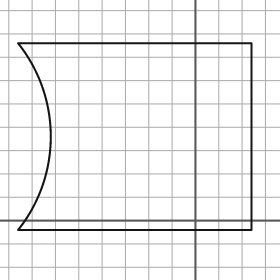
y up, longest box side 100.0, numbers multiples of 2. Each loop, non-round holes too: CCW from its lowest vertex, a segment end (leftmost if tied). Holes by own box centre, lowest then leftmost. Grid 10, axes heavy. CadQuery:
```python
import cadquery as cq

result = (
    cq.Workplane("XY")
    .moveTo(-76.0, -4.0)
    .lineTo(24.0, -4.0)
    .lineTo(24.0, 76.0)
    .lineTo(-76.0, 76.0)
    .threePointArc((-62.0, 36.0), (-76.0, -4.0))
    .close()
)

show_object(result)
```